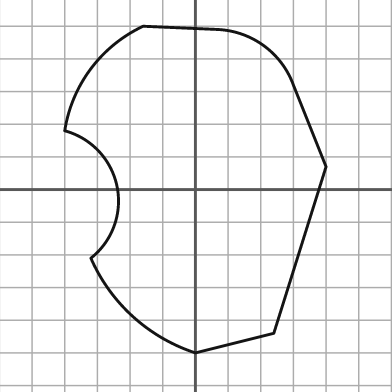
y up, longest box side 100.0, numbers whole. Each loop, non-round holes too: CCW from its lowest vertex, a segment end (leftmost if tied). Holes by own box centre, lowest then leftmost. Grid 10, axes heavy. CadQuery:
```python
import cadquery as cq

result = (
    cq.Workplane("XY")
    .moveTo(0.0, -50.0)
    .lineTo(24.0, -44.0)
    .lineTo(40.0, 7.0)
    .lineTo(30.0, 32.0)
    .threePointArc((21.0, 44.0), (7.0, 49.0))
    .lineTo(-16.0, 50.0)
    .threePointArc((-32.0, 37.0), (-40.0, 18.0))
    .threePointArc((-24.0, 1.0), (-32.0, -21.0))
    .threePointArc((-19.0, -39.0), (0.0, -50.0))
    .close()
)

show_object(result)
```